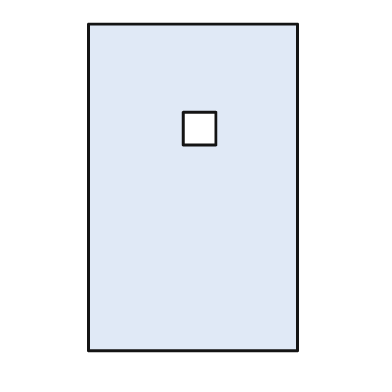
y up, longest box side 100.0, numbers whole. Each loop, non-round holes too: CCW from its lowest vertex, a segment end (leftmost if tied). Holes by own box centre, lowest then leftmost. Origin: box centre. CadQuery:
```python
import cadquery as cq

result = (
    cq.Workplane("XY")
    .moveTo(-32.0, -50.0)
    .lineTo(32.0, -50.0)
    .lineTo(32.0, 50.0)
    .lineTo(-32.0, 50.0)
    .close()
    .moveTo(-3.0, 13.0)
    .lineTo(7.0, 13.0)
    .lineTo(7.0, 23.0)
    .lineTo(-3.0, 23.0)
    .close()
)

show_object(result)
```